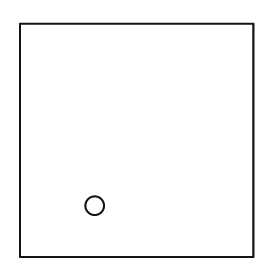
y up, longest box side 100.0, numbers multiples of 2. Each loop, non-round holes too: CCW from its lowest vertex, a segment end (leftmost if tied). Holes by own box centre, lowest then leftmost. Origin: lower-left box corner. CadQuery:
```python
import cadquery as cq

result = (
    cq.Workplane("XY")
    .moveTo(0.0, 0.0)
    .lineTo(100.0, 0.0)
    .lineTo(100.0, 100.0)
    .lineTo(0.0, 100.0)
    .close()
    .moveTo(32.0, 22.0)
    .circle(4.0)
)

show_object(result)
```